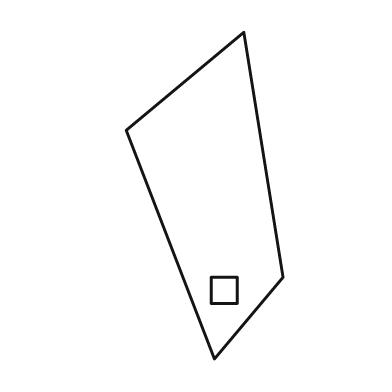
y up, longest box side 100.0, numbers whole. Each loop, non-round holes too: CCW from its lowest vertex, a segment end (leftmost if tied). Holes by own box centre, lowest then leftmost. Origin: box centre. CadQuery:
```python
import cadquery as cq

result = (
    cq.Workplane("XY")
    .moveTo(3.0, -50.0)
    .lineTo(24.0, -25.0)
    .lineTo(12.0, 50.0)
    .lineTo(-24.0, 20.0)
    .close()
    .moveTo(2.0, -33.0)
    .lineTo(10.0, -33.0)
    .lineTo(10.0, -25.0)
    .lineTo(2.0, -25.0)
    .close()
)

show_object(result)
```